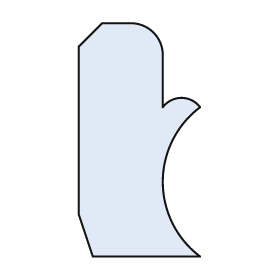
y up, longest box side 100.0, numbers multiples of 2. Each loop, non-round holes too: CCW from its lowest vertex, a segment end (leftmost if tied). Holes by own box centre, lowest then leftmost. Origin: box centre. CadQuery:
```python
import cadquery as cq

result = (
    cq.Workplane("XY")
    .moveTo(-20.0, -50.0)
    .lineTo(26.0, -50.0)
    .threePointArc((10.0, -18.0), (26.0, 14.0))
    .threePointArc((18.0, 18.0), (10.0, 14.0))
    .lineTo(10.0, 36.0)
    .threePointArc((6.0, 46.0), (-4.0, 50.0))
    .lineTo(-16.0, 50.0)
    .lineTo(-26.0, 40.0)
    .lineTo(-26.0, -32.0)
    .close()
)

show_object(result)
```